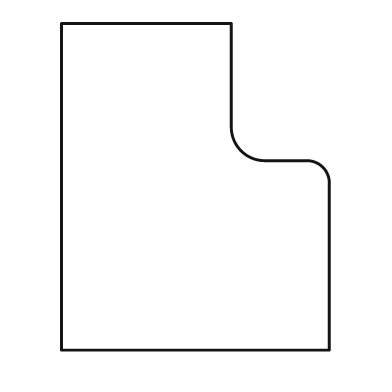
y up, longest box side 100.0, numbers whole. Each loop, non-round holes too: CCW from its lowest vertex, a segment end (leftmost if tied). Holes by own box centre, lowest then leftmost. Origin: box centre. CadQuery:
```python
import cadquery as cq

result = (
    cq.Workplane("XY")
    .moveTo(-41.0, -50.0)
    .lineTo(41.0, -50.0)
    .lineTo(41.0, 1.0)
    .threePointArc((39.0, 6.0), (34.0, 8.0))
    .lineTo(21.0, 8.0)
    .threePointArc((14.0, 11.0), (11.0, 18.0))
    .lineTo(11.0, 50.0)
    .lineTo(-41.0, 50.0)
    .close()
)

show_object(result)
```